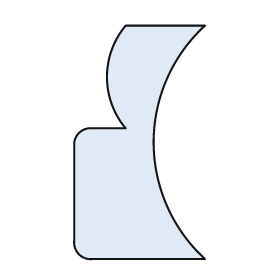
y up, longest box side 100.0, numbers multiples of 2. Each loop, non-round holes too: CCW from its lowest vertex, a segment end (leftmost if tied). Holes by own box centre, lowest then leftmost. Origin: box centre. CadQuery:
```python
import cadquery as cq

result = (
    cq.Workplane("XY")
    .moveTo(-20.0, -50.0)
    .lineTo(28.0, -50.0)
    .threePointArc((6.0, 0.0), (28.0, 50.0))
    .lineTo(-6.0, 50.0)
    .threePointArc((-14.0, 28.0), (-6.0, 6.0))
    .lineTo(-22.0, 6.0)
    .threePointArc((-26.0, 4.0), (-28.0, 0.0))
    .lineTo(-28.0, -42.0)
    .threePointArc((-26.0, -48.0), (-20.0, -50.0))
    .close()
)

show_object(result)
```